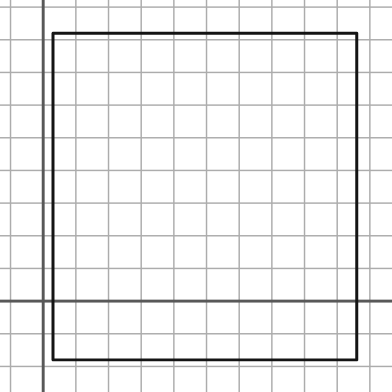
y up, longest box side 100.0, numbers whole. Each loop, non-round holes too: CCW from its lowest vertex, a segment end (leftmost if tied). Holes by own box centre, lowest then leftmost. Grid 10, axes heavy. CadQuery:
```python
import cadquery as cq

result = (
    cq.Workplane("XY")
    .moveTo(3.0, -18.0)
    .lineTo(96.0, -18.0)
    .lineTo(96.0, 82.0)
    .lineTo(3.0, 82.0)
    .close()
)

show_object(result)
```